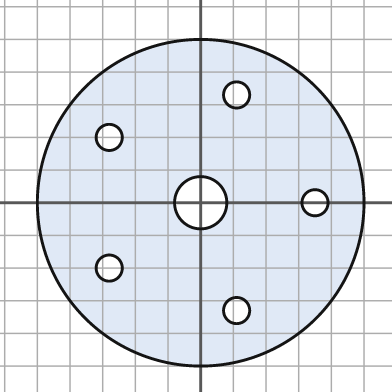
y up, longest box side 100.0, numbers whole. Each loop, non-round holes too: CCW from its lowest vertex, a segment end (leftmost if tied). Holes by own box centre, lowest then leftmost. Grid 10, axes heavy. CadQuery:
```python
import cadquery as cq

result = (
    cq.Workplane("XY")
    .moveTo(0.0, 0.0)
    .circle(50.0)
    .moveTo(11.0, -33.0)
    .circle(4.0)
    .moveTo(-28.0, -20.0)
    .circle(4.0)
    .moveTo(0.0, 0.0)
    .circle(8.0)
    .moveTo(35.0, 0.0)
    .circle(4.0)
    .moveTo(-28.0, 20.0)
    .circle(4.0)
    .moveTo(11.0, 33.0)
    .circle(4.0)
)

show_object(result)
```